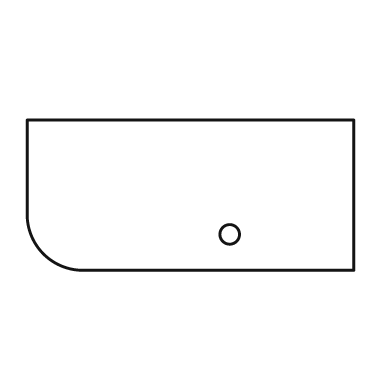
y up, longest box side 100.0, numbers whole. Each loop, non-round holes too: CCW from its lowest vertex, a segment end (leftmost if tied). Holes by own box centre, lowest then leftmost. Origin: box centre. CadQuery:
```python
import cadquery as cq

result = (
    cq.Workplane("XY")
    .moveTo(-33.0, -23.0)
    .lineTo(50.0, -23.0)
    .lineTo(50.0, 23.0)
    .lineTo(-50.0, 23.0)
    .lineTo(-50.0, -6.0)
    .threePointArc((-45.0, -18.0), (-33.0, -23.0))
    .close()
    .moveTo(12.0, -12.0)
    .circle(3.0)
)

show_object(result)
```